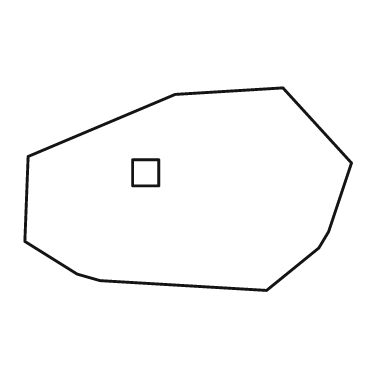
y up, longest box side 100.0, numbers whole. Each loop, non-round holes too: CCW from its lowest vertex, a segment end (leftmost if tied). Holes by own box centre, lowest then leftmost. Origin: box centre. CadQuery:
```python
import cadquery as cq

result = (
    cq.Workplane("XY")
    .moveTo(24.0, -31.0)
    .lineTo(40.0, -18.0)
    .lineTo(43.0, -13.0)
    .lineTo(50.0, 8.0)
    .lineTo(29.0, 31.0)
    .lineTo(-4.0, 29.0)
    .lineTo(-49.0, 10.0)
    .lineTo(-50.0, -16.0)
    .lineTo(-34.0, -26.0)
    .lineTo(-27.0, -28.0)
    .close()
    .moveTo(-17.0, 1.0)
    .lineTo(-9.0, 1.0)
    .lineTo(-9.0, 9.0)
    .lineTo(-17.0, 9.0)
    .close()
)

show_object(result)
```